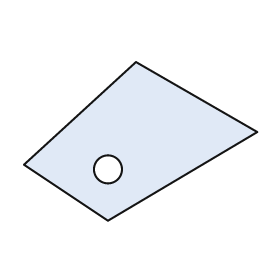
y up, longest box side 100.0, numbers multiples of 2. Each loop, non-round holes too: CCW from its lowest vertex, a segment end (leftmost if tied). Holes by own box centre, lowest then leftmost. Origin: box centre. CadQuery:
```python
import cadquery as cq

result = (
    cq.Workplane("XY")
    .moveTo(-14.0, -34.0)
    .lineTo(50.0, 4.0)
    .lineTo(-2.0, 34.0)
    .lineTo(-50.0, -10.0)
    .close()
    .moveTo(-14.0, -12.0)
    .circle(6.0)
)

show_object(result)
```